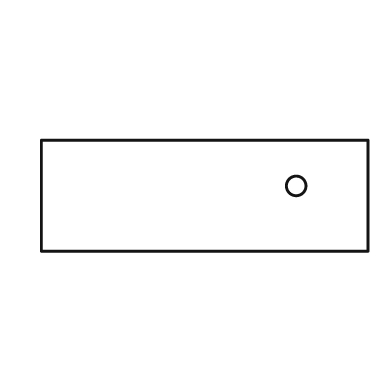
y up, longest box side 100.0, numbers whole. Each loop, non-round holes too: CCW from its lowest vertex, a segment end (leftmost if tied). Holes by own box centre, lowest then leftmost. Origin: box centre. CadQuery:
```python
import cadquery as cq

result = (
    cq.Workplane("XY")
    .moveTo(-50.0, -17.0)
    .lineTo(50.0, -17.0)
    .lineTo(50.0, 17.0)
    .lineTo(-50.0, 17.0)
    .close()
    .moveTo(28.0, 3.0)
    .circle(3.0)
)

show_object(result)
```